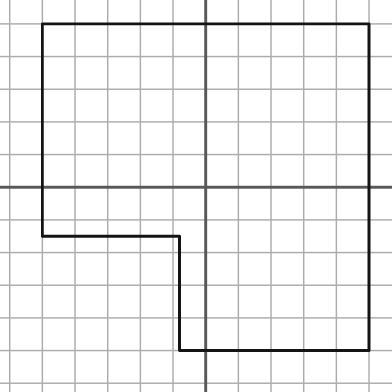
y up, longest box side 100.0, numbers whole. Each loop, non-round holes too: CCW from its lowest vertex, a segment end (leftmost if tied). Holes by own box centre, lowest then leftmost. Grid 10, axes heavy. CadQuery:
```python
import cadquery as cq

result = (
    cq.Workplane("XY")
    .moveTo(-8.0, -50.0)
    .lineTo(50.0, -50.0)
    .lineTo(50.0, 50.0)
    .lineTo(-50.0, 50.0)
    .lineTo(-50.0, -15.0)
    .lineTo(-8.0, -15.0)
    .close()
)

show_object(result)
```